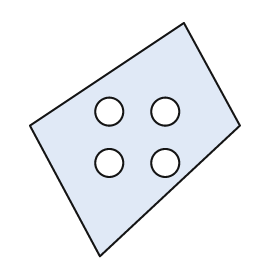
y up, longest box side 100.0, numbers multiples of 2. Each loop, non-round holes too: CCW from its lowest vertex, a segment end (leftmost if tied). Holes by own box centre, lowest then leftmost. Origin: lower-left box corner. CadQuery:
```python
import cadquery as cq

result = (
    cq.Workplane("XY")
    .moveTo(30.0, 0.0)
    .lineTo(90.0, 56.0)
    .lineTo(66.0, 100.0)
    .lineTo(0.0, 56.0)
    .close()
    .moveTo(34.0, 40.0)
    .circle(6.0)
    .moveTo(58.0, 40.0)
    .circle(6.0)
    .moveTo(34.0, 62.0)
    .circle(6.0)
    .moveTo(58.0, 62.0)
    .circle(6.0)
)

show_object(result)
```